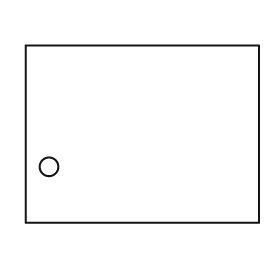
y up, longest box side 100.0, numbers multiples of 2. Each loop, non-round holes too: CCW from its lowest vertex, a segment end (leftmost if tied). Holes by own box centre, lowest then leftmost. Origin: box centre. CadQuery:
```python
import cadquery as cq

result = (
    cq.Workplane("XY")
    .moveTo(-50.0, -38.0)
    .lineTo(50.0, -38.0)
    .lineTo(50.0, 38.0)
    .lineTo(-50.0, 38.0)
    .close()
    .moveTo(-40.0, -14.0)
    .circle(4.0)
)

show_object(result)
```